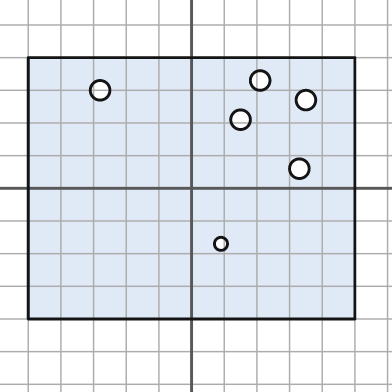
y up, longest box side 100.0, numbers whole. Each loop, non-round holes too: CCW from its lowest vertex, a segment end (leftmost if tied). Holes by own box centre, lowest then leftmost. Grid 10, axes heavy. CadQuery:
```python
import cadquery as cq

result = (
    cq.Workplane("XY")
    .moveTo(-50.0, -40.0)
    .lineTo(50.0, -40.0)
    .lineTo(50.0, 40.0)
    .lineTo(-50.0, 40.0)
    .close()
    .moveTo(9.0, -17.0)
    .circle(2.0)
    .moveTo(33.0, 6.0)
    .circle(3.0)
    .moveTo(15.0, 21.0)
    .circle(3.0)
    .moveTo(35.0, 27.0)
    .circle(3.0)
    .moveTo(-28.0, 30.0)
    .circle(3.0)
    .moveTo(21.0, 33.0)
    .circle(3.0)
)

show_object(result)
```